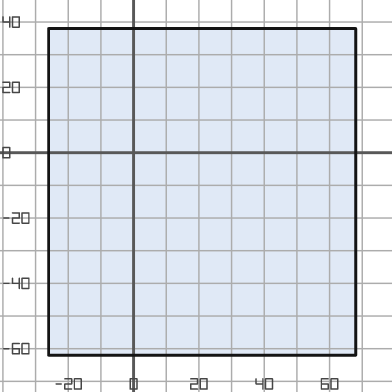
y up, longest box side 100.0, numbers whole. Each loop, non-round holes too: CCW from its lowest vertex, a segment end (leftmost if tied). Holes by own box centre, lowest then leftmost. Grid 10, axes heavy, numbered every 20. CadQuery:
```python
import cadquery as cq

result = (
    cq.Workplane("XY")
    .moveTo(-26.0, -62.0)
    .lineTo(68.0, -62.0)
    .lineTo(68.0, 38.0)
    .lineTo(-26.0, 38.0)
    .close()
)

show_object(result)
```